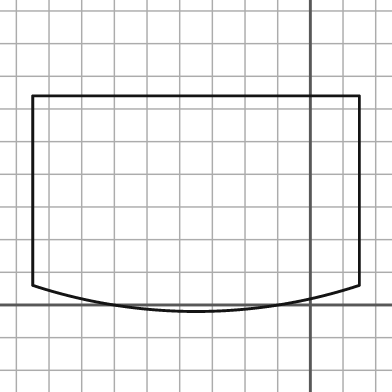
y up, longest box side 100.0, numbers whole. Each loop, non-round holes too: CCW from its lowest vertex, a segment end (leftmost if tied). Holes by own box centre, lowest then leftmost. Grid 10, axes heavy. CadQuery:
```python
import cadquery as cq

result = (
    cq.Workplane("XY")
    .moveTo(-85.0, 6.0)
    .threePointArc((-35.0, -2.0), (15.0, 6.0))
    .lineTo(15.0, 64.0)
    .lineTo(-85.0, 64.0)
    .close()
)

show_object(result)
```